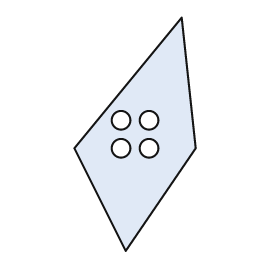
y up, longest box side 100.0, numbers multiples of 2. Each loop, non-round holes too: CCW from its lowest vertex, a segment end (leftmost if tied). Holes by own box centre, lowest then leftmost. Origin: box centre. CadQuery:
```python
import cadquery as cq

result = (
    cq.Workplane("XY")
    .moveTo(-4.0, -50.0)
    .lineTo(26.0, -6.0)
    .lineTo(20.0, 50.0)
    .lineTo(-26.0, -6.0)
    .close()
    .moveTo(-6.0, -6.0)
    .circle(4.0)
    .moveTo(6.0, -6.0)
    .circle(4.0)
    .moveTo(-6.0, 6.0)
    .circle(4.0)
    .moveTo(6.0, 6.0)
    .circle(4.0)
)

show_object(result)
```